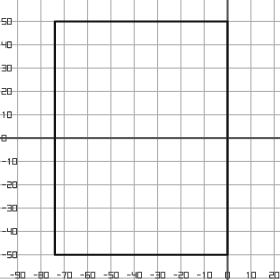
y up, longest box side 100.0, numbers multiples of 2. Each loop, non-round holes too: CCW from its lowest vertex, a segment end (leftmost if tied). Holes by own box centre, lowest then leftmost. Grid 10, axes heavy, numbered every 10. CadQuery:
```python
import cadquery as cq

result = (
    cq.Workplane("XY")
    .moveTo(-74.0, -50.0)
    .lineTo(0.0, -50.0)
    .lineTo(0.0, 50.0)
    .lineTo(-74.0, 50.0)
    .close()
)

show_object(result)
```